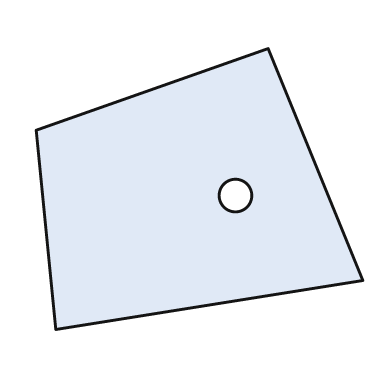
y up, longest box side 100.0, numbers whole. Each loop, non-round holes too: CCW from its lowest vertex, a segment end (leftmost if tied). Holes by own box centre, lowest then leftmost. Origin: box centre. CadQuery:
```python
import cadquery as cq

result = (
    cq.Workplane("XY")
    .moveTo(-44.0, -43.0)
    .lineTo(50.0, -28.0)
    .lineTo(21.0, 43.0)
    .lineTo(-50.0, 18.0)
    .close()
    .moveTo(11.0, -2.0)
    .circle(5.0)
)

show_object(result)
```